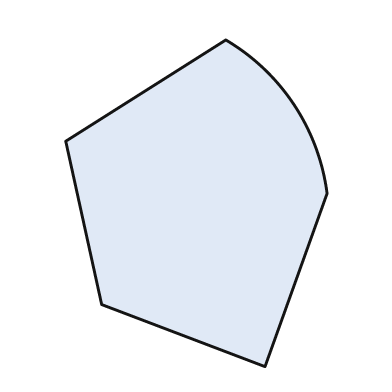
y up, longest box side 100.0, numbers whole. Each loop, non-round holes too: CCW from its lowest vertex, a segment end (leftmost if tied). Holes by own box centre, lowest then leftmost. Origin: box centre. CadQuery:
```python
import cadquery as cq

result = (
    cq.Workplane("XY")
    .moveTo(21.0, -50.0)
    .lineTo(40.0, 3.0)
    .threePointArc((30.0, 30.0), (9.0, 50.0))
    .lineTo(-40.0, 19.0)
    .lineTo(-29.0, -31.0)
    .close()
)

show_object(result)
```